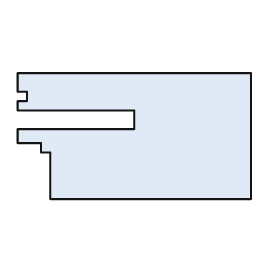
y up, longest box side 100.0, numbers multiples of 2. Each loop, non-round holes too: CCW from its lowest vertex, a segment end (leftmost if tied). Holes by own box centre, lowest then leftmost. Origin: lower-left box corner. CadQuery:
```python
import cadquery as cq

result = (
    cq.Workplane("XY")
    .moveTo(14.0, 0.0)
    .lineTo(100.0, 0.0)
    .lineTo(100.0, 54.0)
    .lineTo(0.0, 54.0)
    .lineTo(0.0, 46.0)
    .lineTo(4.0, 46.0)
    .lineTo(4.0, 42.0)
    .lineTo(0.0, 42.0)
    .lineTo(0.0, 38.0)
    .lineTo(50.0, 38.0)
    .lineTo(50.0, 30.0)
    .lineTo(0.0, 30.0)
    .lineTo(0.0, 24.0)
    .lineTo(10.0, 24.0)
    .lineTo(10.0, 20.0)
    .lineTo(14.0, 20.0)
    .close()
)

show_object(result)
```